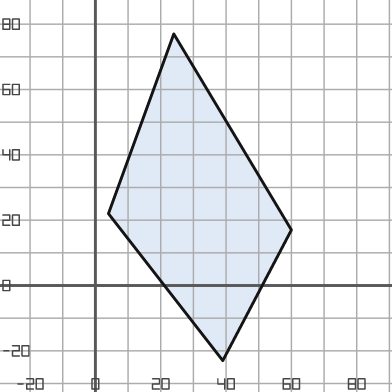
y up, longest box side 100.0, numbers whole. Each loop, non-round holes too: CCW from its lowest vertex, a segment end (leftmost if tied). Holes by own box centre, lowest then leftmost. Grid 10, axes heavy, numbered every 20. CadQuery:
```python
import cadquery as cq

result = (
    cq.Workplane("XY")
    .moveTo(39.0, -23.0)
    .lineTo(60.0, 17.0)
    .lineTo(24.0, 77.0)
    .lineTo(4.0, 22.0)
    .close()
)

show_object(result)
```